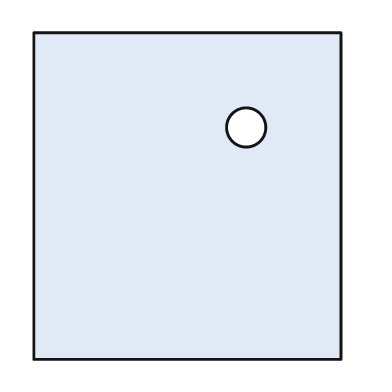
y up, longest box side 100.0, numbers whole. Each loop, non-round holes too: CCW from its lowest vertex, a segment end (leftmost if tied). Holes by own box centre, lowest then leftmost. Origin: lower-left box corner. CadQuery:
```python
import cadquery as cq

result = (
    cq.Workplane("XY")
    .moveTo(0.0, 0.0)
    .lineTo(94.0, 0.0)
    .lineTo(94.0, 100.0)
    .lineTo(0.0, 100.0)
    .close()
    .moveTo(65.0, 71.0)
    .circle(6.0)
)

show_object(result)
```